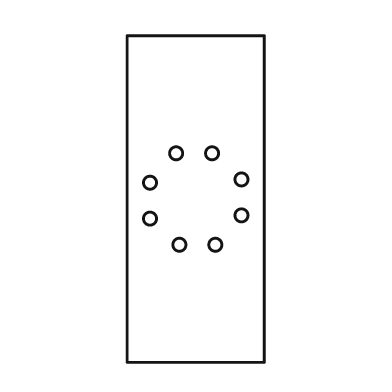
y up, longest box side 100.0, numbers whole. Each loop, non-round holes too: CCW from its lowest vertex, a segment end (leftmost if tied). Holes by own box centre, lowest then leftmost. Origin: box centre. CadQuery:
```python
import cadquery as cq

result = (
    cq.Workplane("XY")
    .moveTo(-21.0, -50.0)
    .lineTo(21.0, -50.0)
    .lineTo(21.0, 50.0)
    .lineTo(-21.0, 50.0)
    .close()
    .moveTo(-5.0, -14.0)
    .circle(2.0)
    .moveTo(6.0, -14.0)
    .circle(2.0)
    .moveTo(-14.0, -6.0)
    .circle(2.0)
    .moveTo(14.0, -5.0)
    .circle(2.0)
    .moveTo(-14.0, 5.0)
    .circle(2.0)
    .moveTo(14.0, 6.0)
    .circle(2.0)
    .moveTo(-6.0, 14.0)
    .circle(2.0)
    .moveTo(5.0, 14.0)
    .circle(2.0)
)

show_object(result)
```